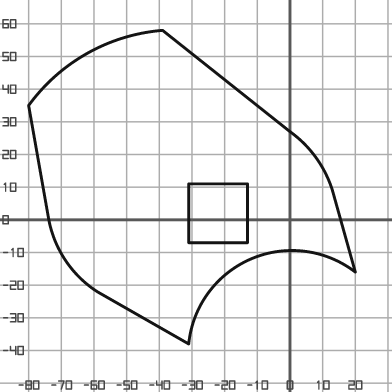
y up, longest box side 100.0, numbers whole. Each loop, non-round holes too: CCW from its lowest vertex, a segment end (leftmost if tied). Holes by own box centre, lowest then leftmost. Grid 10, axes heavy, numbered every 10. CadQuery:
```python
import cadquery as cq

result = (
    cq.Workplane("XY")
    .moveTo(-31.0, -38.0)
    .threePointArc((-12.0, -12.0), (20.0, -16.0))
    .lineTo(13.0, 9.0)
    .threePointArc((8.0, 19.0), (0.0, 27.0))
    .lineTo(-39.0, 58.0)
    .threePointArc((-62.0, 51.0), (-80.0, 35.0))
    .lineTo(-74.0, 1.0)
    .threePointArc((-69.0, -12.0), (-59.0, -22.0))
    .close()
    .moveTo(-31.0, -7.0)
    .lineTo(-13.0, -7.0)
    .lineTo(-13.0, 11.0)
    .lineTo(-31.0, 11.0)
    .close()
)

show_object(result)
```